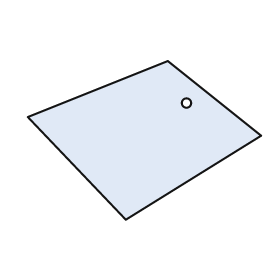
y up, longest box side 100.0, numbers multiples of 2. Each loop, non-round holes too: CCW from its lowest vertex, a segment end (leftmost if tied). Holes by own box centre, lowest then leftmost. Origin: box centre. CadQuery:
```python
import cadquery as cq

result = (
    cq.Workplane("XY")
    .moveTo(-8.0, -34.0)
    .lineTo(50.0, 2.0)
    .lineTo(10.0, 34.0)
    .lineTo(-50.0, 10.0)
    .close()
    .moveTo(18.0, 16.0)
    .circle(2.0)
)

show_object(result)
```